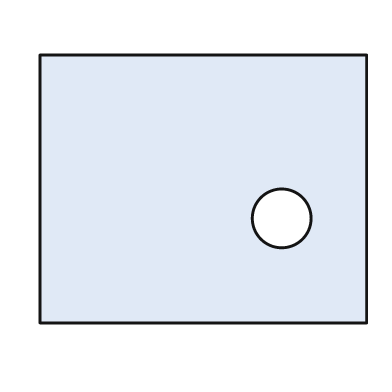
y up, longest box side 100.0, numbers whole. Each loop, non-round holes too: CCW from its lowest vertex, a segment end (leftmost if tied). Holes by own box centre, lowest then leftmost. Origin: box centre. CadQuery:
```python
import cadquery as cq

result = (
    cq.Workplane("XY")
    .moveTo(-50.0, -41.0)
    .lineTo(50.0, -41.0)
    .lineTo(50.0, 41.0)
    .lineTo(-50.0, 41.0)
    .close()
    .moveTo(24.0, -9.0)
    .circle(9.0)
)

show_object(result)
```